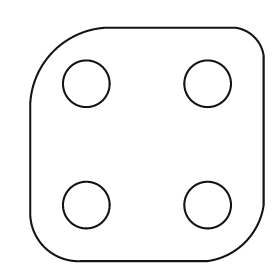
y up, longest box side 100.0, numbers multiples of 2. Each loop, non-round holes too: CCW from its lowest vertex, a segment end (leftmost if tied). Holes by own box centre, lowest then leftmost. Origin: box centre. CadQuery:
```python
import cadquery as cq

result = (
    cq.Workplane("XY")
    .moveTo(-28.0, -50.0)
    .lineTo(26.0, -50.0)
    .threePointArc((42.0, -42.0), (50.0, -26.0))
    .lineTo(50.0, 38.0)
    .threePointArc((46.0, 46.0), (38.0, 50.0))
    .lineTo(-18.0, 50.0)
    .threePointArc((-40.0, 40.0), (-50.0, 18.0))
    .lineTo(-50.0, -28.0)
    .threePointArc((-44.0, -44.0), (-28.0, -50.0))
    .close()
    .moveTo(-26.0, -26.0)
    .circle(10.0)
    .moveTo(26.0, -26.0)
    .circle(10.0)
    .moveTo(-26.0, 26.0)
    .circle(10.0)
    .moveTo(26.0, 26.0)
    .circle(10.0)
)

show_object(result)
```